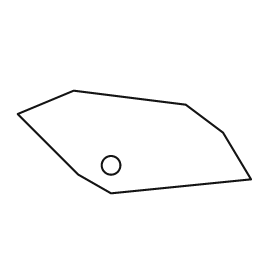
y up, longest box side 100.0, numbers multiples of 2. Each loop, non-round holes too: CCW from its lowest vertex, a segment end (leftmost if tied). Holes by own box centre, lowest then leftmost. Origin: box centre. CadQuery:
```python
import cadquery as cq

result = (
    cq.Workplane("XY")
    .moveTo(-10.0, -22.0)
    .lineTo(50.0, -16.0)
    .lineTo(38.0, 4.0)
    .lineTo(22.0, 16.0)
    .lineTo(-26.0, 22.0)
    .lineTo(-50.0, 12.0)
    .lineTo(-24.0, -14.0)
    .close()
    .moveTo(-10.0, -10.0)
    .circle(4.0)
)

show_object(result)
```